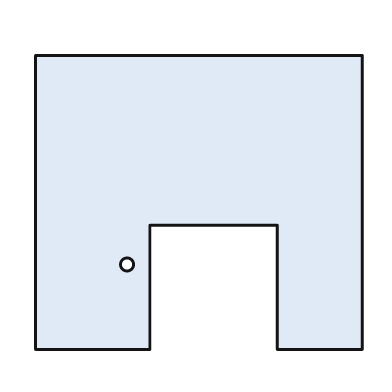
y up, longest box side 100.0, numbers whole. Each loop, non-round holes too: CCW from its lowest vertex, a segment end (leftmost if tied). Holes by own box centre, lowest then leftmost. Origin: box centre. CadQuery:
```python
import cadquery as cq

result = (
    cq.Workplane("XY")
    .moveTo(-50.0, -45.0)
    .lineTo(-15.0, -45.0)
    .lineTo(-15.0, -7.0)
    .lineTo(24.0, -7.0)
    .lineTo(24.0, -45.0)
    .lineTo(50.0, -45.0)
    .lineTo(50.0, 45.0)
    .lineTo(-50.0, 45.0)
    .close()
    .moveTo(-22.0, -19.0)
    .circle(2.0)
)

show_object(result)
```